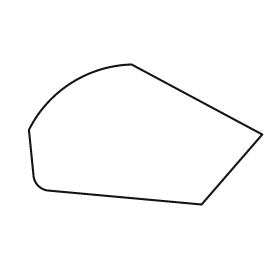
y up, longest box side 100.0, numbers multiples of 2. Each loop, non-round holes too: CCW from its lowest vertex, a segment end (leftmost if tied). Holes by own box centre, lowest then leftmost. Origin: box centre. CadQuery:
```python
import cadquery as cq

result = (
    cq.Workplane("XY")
    .moveTo(24.0, -30.0)
    .lineTo(50.0, 0.0)
    .lineTo(-6.0, 30.0)
    .threePointArc((-32.0, 22.0), (-50.0, 2.0))
    .lineTo(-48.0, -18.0)
    .threePointArc((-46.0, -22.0), (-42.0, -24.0))
    .close()
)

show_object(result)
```